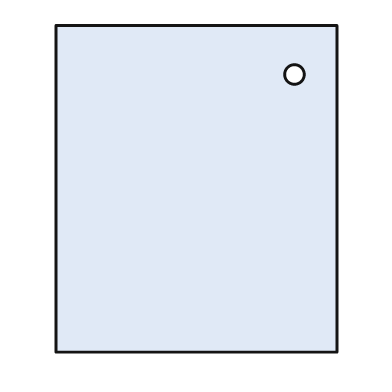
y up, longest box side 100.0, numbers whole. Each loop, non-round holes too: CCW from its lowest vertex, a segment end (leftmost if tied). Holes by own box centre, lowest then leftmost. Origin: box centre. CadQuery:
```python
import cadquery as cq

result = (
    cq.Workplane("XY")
    .moveTo(-43.0, -50.0)
    .lineTo(43.0, -50.0)
    .lineTo(43.0, 50.0)
    .lineTo(-43.0, 50.0)
    .close()
    .moveTo(30.0, 35.0)
    .circle(3.0)
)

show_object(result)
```